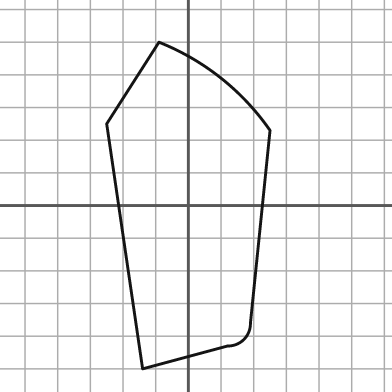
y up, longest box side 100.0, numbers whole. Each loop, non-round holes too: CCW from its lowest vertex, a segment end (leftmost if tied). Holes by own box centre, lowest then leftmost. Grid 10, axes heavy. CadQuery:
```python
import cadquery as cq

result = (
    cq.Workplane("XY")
    .moveTo(-14.0, -50.0)
    .lineTo(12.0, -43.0)
    .threePointArc((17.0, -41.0), (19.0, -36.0))
    .lineTo(25.0, 23.0)
    .threePointArc((10.0, 39.0), (-9.0, 50.0))
    .lineTo(-25.0, 25.0)
    .close()
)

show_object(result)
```